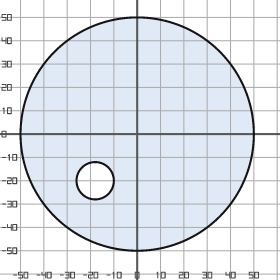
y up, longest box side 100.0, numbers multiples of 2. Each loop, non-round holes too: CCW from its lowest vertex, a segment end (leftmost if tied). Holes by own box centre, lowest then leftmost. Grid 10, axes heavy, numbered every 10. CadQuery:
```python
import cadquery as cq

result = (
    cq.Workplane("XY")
    .moveTo(0.0, 0.0)
    .circle(50.0)
    .moveTo(-18.0, -20.0)
    .circle(8.0)
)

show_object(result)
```